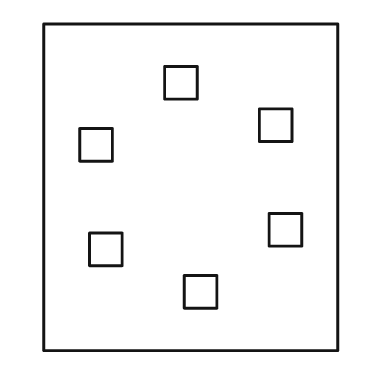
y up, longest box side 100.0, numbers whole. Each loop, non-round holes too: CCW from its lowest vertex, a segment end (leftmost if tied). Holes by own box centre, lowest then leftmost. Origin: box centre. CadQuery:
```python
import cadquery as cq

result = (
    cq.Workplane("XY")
    .moveTo(-45.0, -50.0)
    .lineTo(45.0, -50.0)
    .lineTo(45.0, 50.0)
    .lineTo(-45.0, 50.0)
    .close()
    .moveTo(-2.0, -37.0)
    .lineTo(8.0, -37.0)
    .lineTo(8.0, -27.0)
    .lineTo(-2.0, -27.0)
    .close()
    .moveTo(-31.0, -24.0)
    .lineTo(-21.0, -24.0)
    .lineTo(-21.0, -14.0)
    .lineTo(-31.0, -14.0)
    .close()
    .moveTo(24.0, -18.0)
    .lineTo(34.0, -18.0)
    .lineTo(34.0, -8.0)
    .lineTo(24.0, -8.0)
    .close()
    .moveTo(-34.0, 8.0)
    .lineTo(-24.0, 8.0)
    .lineTo(-24.0, 18.0)
    .lineTo(-34.0, 18.0)
    .close()
    .moveTo(21.0, 14.0)
    .lineTo(31.0, 14.0)
    .lineTo(31.0, 24.0)
    .lineTo(21.0, 24.0)
    .close()
    .moveTo(-8.0, 27.0)
    .lineTo(2.0, 27.0)
    .lineTo(2.0, 37.0)
    .lineTo(-8.0, 37.0)
    .close()
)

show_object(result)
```